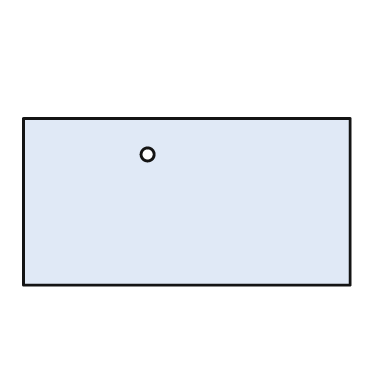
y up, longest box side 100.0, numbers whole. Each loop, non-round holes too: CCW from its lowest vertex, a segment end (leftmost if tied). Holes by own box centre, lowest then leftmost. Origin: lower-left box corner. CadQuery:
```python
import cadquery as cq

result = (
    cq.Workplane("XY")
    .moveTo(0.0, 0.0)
    .lineTo(100.0, 0.0)
    .lineTo(100.0, 51.0)
    .lineTo(0.0, 51.0)
    .close()
    .moveTo(38.0, 40.0)
    .circle(2.0)
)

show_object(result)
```